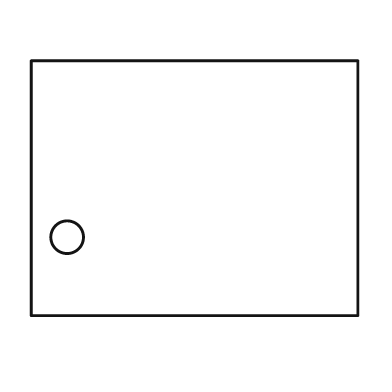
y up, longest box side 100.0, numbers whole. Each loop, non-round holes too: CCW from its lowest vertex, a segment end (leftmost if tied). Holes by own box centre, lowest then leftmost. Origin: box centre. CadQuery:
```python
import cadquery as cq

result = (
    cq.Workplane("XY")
    .moveTo(-50.0, -39.0)
    .lineTo(50.0, -39.0)
    .lineTo(50.0, 39.0)
    .lineTo(-50.0, 39.0)
    .close()
    .moveTo(-39.0, -15.0)
    .circle(5.0)
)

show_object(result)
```